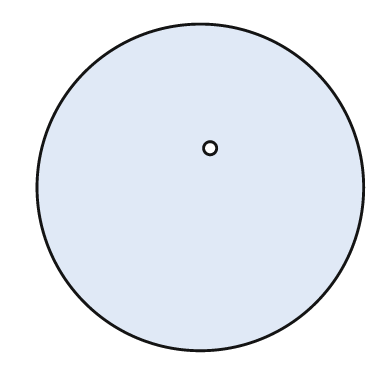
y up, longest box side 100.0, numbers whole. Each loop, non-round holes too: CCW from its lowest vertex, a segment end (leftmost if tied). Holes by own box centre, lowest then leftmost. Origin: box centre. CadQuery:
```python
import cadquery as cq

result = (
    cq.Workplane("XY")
    .moveTo(0.0, 0.0)
    .circle(50.0)
    .moveTo(3.0, 12.0)
    .circle(2.0)
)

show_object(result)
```